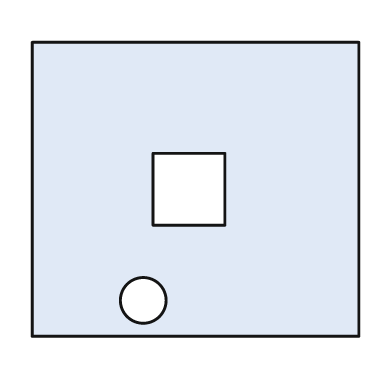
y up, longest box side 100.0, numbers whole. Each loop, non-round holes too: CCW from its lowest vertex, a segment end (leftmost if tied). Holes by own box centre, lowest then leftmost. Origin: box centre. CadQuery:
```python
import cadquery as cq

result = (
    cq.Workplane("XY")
    .moveTo(-50.0, -45.0)
    .lineTo(50.0, -45.0)
    .lineTo(50.0, 45.0)
    .lineTo(-50.0, 45.0)
    .close()
    .moveTo(-16.0, -34.0)
    .circle(7.0)
    .moveTo(-13.0, -11.0)
    .lineTo(9.0, -11.0)
    .lineTo(9.0, 11.0)
    .lineTo(-13.0, 11.0)
    .close()
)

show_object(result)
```